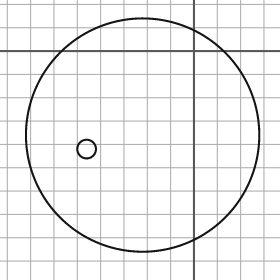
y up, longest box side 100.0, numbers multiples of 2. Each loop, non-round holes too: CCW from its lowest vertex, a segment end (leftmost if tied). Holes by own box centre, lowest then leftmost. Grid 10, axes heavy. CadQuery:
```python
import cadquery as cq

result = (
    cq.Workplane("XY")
    .moveTo(-22.0, -36.0)
    .circle(50.0)
    .moveTo(-46.0, -42.0)
    .circle(4.0)
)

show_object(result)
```